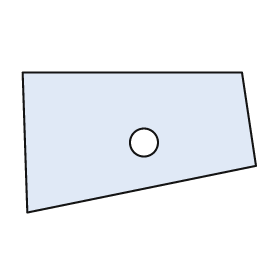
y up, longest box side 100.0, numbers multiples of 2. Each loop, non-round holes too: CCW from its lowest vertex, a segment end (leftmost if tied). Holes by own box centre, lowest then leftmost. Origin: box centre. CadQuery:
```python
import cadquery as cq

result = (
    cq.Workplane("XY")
    .moveTo(-48.0, -30.0)
    .lineTo(50.0, -10.0)
    .lineTo(44.0, 30.0)
    .lineTo(-50.0, 30.0)
    .close()
    .moveTo(2.0, 0.0)
    .circle(6.0)
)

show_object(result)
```